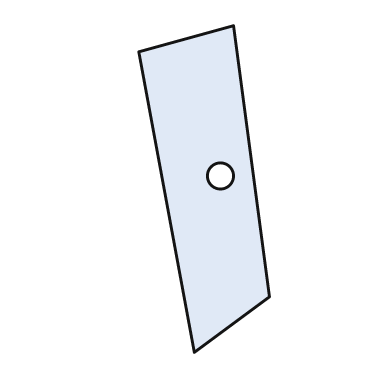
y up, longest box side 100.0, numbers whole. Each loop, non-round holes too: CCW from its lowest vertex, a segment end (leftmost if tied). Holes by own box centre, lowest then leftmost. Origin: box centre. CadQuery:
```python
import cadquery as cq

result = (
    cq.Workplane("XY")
    .moveTo(-3.0, -50.0)
    .lineTo(20.0, -33.0)
    .lineTo(9.0, 50.0)
    .lineTo(-20.0, 42.0)
    .close()
    .moveTo(5.0, 4.0)
    .circle(4.0)
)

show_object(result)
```